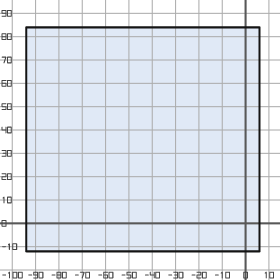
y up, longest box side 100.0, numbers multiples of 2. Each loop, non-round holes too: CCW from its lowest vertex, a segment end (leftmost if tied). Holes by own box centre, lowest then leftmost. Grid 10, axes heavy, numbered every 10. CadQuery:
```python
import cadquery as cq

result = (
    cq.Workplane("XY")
    .moveTo(-94.0, -12.0)
    .lineTo(6.0, -12.0)
    .lineTo(6.0, 84.0)
    .lineTo(-94.0, 84.0)
    .close()
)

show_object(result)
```